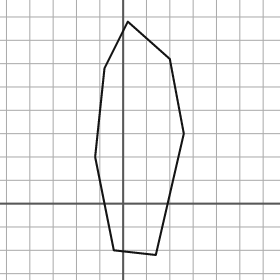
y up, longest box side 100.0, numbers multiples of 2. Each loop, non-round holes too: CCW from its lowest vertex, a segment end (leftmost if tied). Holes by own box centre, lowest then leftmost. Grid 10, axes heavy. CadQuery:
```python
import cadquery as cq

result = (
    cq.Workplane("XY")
    .moveTo(14.0, -22.0)
    .lineTo(26.0, 30.0)
    .lineTo(20.0, 62.0)
    .lineTo(2.0, 78.0)
    .lineTo(-8.0, 58.0)
    .lineTo(-12.0, 20.0)
    .lineTo(-4.0, -20.0)
    .close()
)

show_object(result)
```